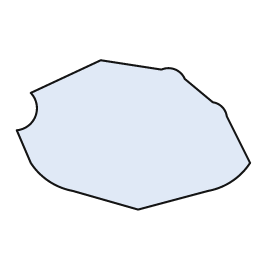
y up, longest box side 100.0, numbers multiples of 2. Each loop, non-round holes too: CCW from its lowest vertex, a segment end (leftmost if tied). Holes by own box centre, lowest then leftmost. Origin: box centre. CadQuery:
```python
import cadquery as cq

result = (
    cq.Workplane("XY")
    .moveTo(2.0, -32.0)
    .lineTo(32.0, -24.0)
    .threePointArc((42.0, -20.0), (50.0, -12.0))
    .lineTo(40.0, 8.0)
    .threePointArc((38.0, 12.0), (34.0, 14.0))
    .lineTo(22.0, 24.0)
    .threePointArc((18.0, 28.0), (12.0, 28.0))
    .lineTo(-14.0, 32.0)
    .lineTo(-44.0, 18.0)
    .threePointArc((-42.0, 8.0), (-50.0, 2.0))
    .lineTo(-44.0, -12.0)
    .threePointArc((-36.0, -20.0), (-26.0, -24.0))
    .close()
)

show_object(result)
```